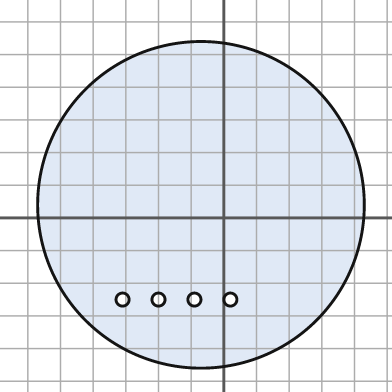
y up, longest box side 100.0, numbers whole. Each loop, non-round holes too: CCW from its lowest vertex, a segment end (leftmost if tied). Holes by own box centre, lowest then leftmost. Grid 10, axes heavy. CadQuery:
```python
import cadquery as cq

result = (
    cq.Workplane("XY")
    .moveTo(-7.0, 4.0)
    .circle(50.0)
    .moveTo(-31.0, -25.0)
    .circle(2.0)
    .moveTo(-20.0, -25.0)
    .circle(2.0)
    .moveTo(-9.0, -25.0)
    .circle(2.0)
    .moveTo(2.0, -25.0)
    .circle(2.0)
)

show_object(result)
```